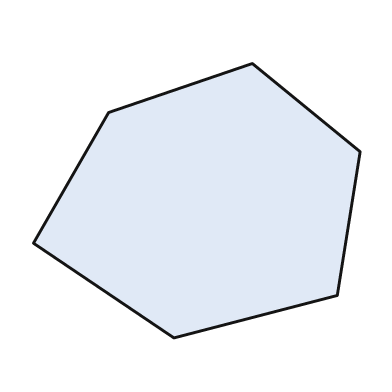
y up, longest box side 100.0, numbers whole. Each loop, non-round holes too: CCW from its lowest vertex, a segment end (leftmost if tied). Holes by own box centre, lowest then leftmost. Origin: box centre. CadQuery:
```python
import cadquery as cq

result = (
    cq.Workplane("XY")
    .moveTo(-7.0, -42.0)
    .lineTo(43.0, -29.0)
    .lineTo(50.0, 15.0)
    .lineTo(17.0, 42.0)
    .lineTo(-27.0, 27.0)
    .lineTo(-50.0, -13.0)
    .close()
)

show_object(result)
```